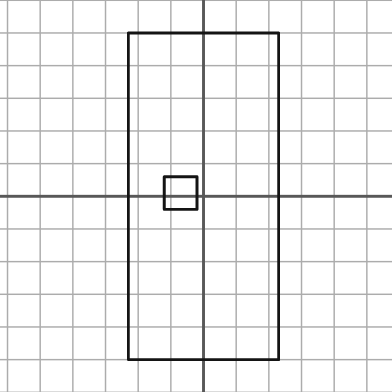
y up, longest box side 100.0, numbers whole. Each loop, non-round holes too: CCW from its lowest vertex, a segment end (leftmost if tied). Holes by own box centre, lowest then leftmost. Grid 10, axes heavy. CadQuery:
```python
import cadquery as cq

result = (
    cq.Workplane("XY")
    .moveTo(-23.0, -50.0)
    .lineTo(23.0, -50.0)
    .lineTo(23.0, 50.0)
    .lineTo(-23.0, 50.0)
    .close()
    .moveTo(-12.0, -4.0)
    .lineTo(-2.0, -4.0)
    .lineTo(-2.0, 6.0)
    .lineTo(-12.0, 6.0)
    .close()
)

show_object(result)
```